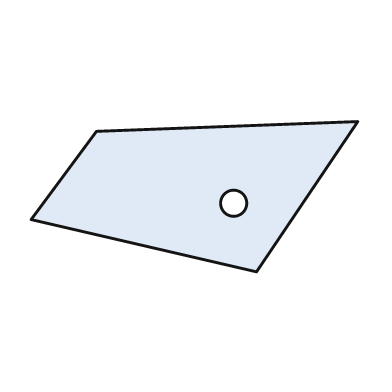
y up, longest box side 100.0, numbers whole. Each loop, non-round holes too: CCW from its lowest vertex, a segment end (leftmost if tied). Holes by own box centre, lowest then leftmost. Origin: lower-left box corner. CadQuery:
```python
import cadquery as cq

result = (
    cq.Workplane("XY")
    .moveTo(69.0, 0.0)
    .lineTo(100.0, 46.0)
    .lineTo(20.0, 43.0)
    .lineTo(0.0, 16.0)
    .close()
    .moveTo(62.0, 21.0)
    .circle(4.0)
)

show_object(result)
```